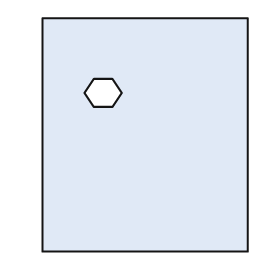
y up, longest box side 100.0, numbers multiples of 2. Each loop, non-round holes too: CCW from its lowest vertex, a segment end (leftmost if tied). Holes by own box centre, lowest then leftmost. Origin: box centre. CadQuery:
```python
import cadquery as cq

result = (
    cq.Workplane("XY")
    .moveTo(-44.0, -50.0)
    .lineTo(44.0, -50.0)
    .lineTo(44.0, 50.0)
    .lineTo(-44.0, 50.0)
    .close()
    .moveTo(-22.0, 12.0)
    .lineTo(-14.0, 12.0)
    .lineTo(-10.0, 18.0)
    .lineTo(-14.0, 24.0)
    .lineTo(-22.0, 24.0)
    .lineTo(-26.0, 18.0)
    .close()
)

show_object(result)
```